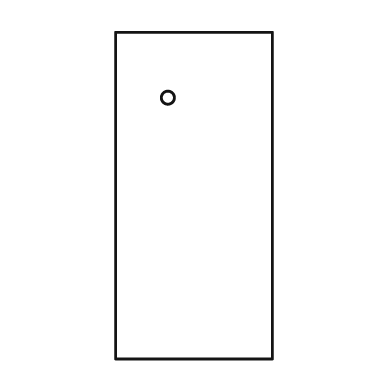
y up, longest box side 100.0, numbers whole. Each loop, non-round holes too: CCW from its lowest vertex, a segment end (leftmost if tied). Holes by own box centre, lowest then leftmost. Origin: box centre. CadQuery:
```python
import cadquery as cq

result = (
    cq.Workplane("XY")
    .moveTo(-24.0, -50.0)
    .lineTo(24.0, -50.0)
    .lineTo(24.0, 50.0)
    .lineTo(-24.0, 50.0)
    .close()
    .moveTo(-8.0, 30.0)
    .circle(2.0)
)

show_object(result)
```